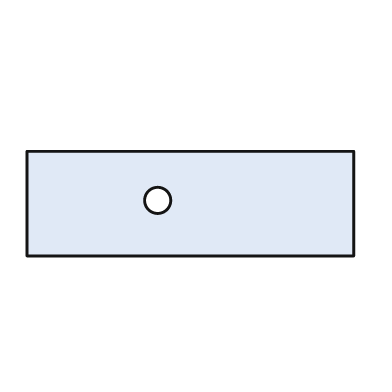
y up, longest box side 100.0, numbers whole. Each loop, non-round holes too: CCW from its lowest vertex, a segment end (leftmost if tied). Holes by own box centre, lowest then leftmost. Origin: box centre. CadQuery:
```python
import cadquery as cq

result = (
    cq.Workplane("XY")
    .moveTo(-50.0, -16.0)
    .lineTo(50.0, -16.0)
    .lineTo(50.0, 16.0)
    .lineTo(-50.0, 16.0)
    .close()
    .moveTo(-10.0, 1.0)
    .circle(4.0)
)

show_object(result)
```